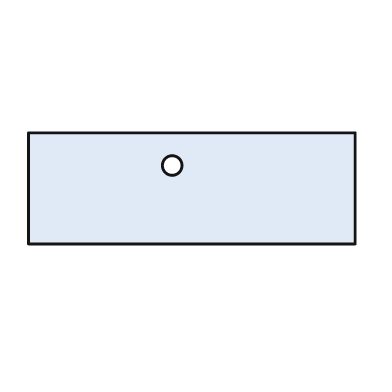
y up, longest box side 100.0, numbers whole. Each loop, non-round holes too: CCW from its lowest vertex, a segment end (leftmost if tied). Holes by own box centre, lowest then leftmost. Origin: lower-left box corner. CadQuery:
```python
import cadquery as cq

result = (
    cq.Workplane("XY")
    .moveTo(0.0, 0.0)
    .lineTo(100.0, 0.0)
    .lineTo(100.0, 34.0)
    .lineTo(0.0, 34.0)
    .close()
    .moveTo(44.0, 24.0)
    .circle(3.0)
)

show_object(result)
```